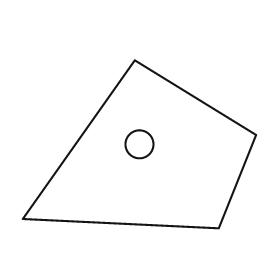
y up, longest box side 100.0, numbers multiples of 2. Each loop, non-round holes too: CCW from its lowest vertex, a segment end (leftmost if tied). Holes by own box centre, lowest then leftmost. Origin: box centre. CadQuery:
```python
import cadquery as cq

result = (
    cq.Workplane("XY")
    .moveTo(34.0, -36.0)
    .lineTo(50.0, 4.0)
    .lineTo(-2.0, 36.0)
    .lineTo(-50.0, -32.0)
    .close()
    .moveTo(0.0, 0.0)
    .circle(6.0)
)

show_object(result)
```